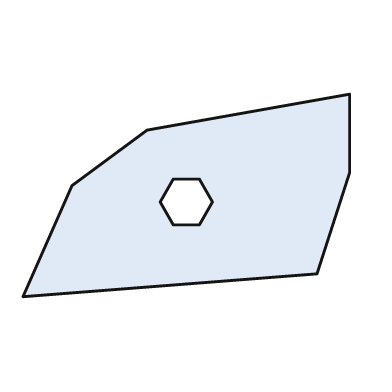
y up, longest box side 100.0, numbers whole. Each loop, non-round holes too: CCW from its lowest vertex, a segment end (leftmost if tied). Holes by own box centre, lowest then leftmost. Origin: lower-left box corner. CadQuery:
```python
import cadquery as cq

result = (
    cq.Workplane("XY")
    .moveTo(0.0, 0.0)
    .lineTo(90.0, 7.0)
    .lineTo(100.0, 38.0)
    .lineTo(100.0, 62.0)
    .lineTo(38.0, 51.0)
    .lineTo(15.0, 34.0)
    .close()
    .moveTo(46.0, 22.0)
    .lineTo(54.0, 22.0)
    .lineTo(58.0, 29.0)
    .lineTo(54.0, 36.0)
    .lineTo(46.0, 36.0)
    .lineTo(42.0, 29.0)
    .close()
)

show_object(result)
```